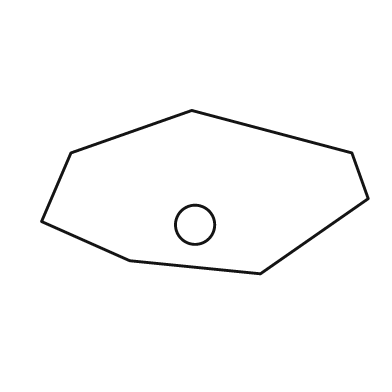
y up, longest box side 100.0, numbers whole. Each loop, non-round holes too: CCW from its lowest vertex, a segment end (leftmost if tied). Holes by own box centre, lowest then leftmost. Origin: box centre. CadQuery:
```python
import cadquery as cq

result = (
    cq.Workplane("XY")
    .moveTo(17.0, -25.0)
    .lineTo(50.0, -2.0)
    .lineTo(45.0, 12.0)
    .lineTo(-4.0, 25.0)
    .lineTo(-41.0, 12.0)
    .lineTo(-50.0, -9.0)
    .lineTo(-23.0, -21.0)
    .close()
    .moveTo(-3.0, -10.0)
    .circle(6.0)
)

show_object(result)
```